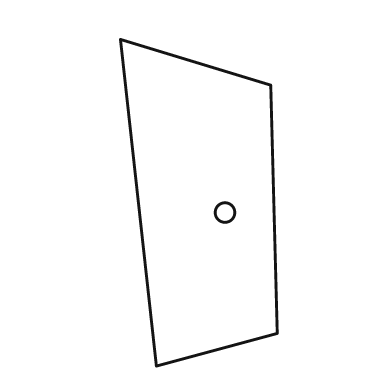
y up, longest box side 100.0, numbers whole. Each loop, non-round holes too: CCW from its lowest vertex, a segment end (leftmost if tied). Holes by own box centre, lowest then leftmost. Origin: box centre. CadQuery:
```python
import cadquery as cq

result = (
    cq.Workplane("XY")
    .moveTo(-13.0, -50.0)
    .lineTo(24.0, -40.0)
    .lineTo(22.0, 36.0)
    .lineTo(-24.0, 50.0)
    .close()
    .moveTo(8.0, -3.0)
    .circle(3.0)
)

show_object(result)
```